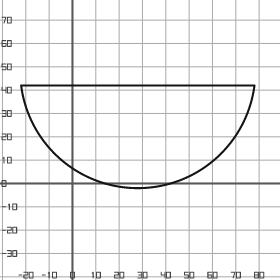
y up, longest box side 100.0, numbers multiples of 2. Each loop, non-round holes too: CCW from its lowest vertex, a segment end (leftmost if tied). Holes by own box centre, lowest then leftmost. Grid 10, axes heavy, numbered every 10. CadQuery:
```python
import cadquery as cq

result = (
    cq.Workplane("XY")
    .moveTo(-22.0, 42.0)
    .threePointArc((28.0, -2.0), (78.0, 42.0))
    .close()
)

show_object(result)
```